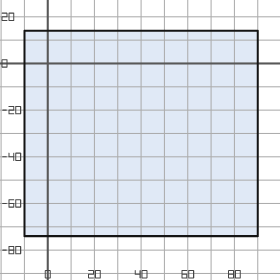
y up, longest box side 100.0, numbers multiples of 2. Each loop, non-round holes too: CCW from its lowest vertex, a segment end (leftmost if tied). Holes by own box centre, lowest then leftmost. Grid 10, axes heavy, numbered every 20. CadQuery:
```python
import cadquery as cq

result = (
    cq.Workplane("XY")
    .moveTo(-10.0, -74.0)
    .lineTo(90.0, -74.0)
    .lineTo(90.0, 14.0)
    .lineTo(-10.0, 14.0)
    .close()
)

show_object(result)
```